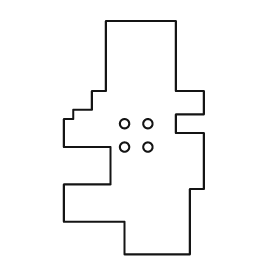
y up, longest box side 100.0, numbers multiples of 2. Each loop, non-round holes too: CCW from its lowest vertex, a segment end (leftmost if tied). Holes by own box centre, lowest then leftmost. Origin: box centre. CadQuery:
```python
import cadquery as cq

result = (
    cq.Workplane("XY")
    .moveTo(-4.0, -50.0)
    .lineTo(24.0, -50.0)
    .lineTo(24.0, -22.0)
    .lineTo(30.0, -22.0)
    .lineTo(30.0, 2.0)
    .lineTo(18.0, 2.0)
    .lineTo(18.0, 10.0)
    .lineTo(30.0, 10.0)
    .lineTo(30.0, 20.0)
    .lineTo(18.0, 20.0)
    .lineTo(18.0, 50.0)
    .lineTo(-12.0, 50.0)
    .lineTo(-12.0, 20.0)
    .lineTo(-18.0, 20.0)
    .lineTo(-18.0, 12.0)
    .lineTo(-26.0, 12.0)
    .lineTo(-26.0, 8.0)
    .lineTo(-30.0, 8.0)
    .lineTo(-30.0, -4.0)
    .lineTo(-10.0, -4.0)
    .lineTo(-10.0, -20.0)
    .lineTo(-30.0, -20.0)
    .lineTo(-30.0, -36.0)
    .lineTo(-4.0, -36.0)
    .close()
    .moveTo(-4.0, -4.0)
    .circle(2.0)
    .moveTo(6.0, -4.0)
    .circle(2.0)
    .moveTo(-4.0, 6.0)
    .circle(2.0)
    .moveTo(6.0, 6.0)
    .circle(2.0)
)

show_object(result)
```